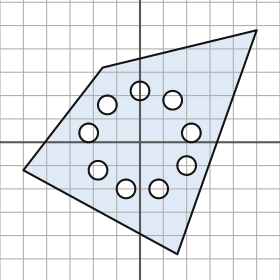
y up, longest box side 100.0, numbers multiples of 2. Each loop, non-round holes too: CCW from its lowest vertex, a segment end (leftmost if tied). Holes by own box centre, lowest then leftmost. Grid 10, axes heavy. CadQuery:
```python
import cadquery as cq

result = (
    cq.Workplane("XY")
    .moveTo(16.0, -48.0)
    .lineTo(50.0, 48.0)
    .lineTo(-16.0, 32.0)
    .lineTo(-50.0, -12.0)
    .close()
    .moveTo(-6.0, -20.0)
    .circle(4.0)
    .moveTo(8.0, -20.0)
    .circle(4.0)
    .moveTo(-18.0, -12.0)
    .circle(4.0)
    .moveTo(20.0, -10.0)
    .circle(4.0)
    .moveTo(-22.0, 4.0)
    .circle(4.0)
    .moveTo(22.0, 4.0)
    .circle(4.0)
    .moveTo(-14.0, 16.0)
    .circle(4.0)
    .moveTo(14.0, 18.0)
    .circle(4.0)
    .moveTo(0.0, 22.0)
    .circle(4.0)
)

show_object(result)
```